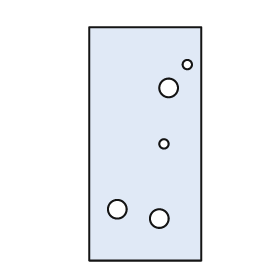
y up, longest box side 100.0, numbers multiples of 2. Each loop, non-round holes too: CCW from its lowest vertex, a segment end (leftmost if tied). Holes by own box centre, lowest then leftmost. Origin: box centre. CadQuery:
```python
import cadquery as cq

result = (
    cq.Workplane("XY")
    .moveTo(-24.0, -50.0)
    .lineTo(24.0, -50.0)
    .lineTo(24.0, 50.0)
    .lineTo(-24.0, 50.0)
    .close()
    .moveTo(6.0, -32.0)
    .circle(4.0)
    .moveTo(-12.0, -28.0)
    .circle(4.0)
    .moveTo(8.0, 0.0)
    .circle(2.0)
    .moveTo(10.0, 24.0)
    .circle(4.0)
    .moveTo(18.0, 34.0)
    .circle(2.0)
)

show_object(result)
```